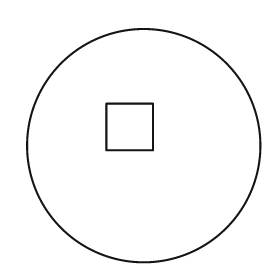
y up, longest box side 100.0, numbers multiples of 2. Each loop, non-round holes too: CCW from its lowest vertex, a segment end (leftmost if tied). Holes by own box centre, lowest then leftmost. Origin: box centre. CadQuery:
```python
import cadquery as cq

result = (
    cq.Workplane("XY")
    .moveTo(0.0, 0.0)
    .circle(50.0)
    .moveTo(-16.0, -2.0)
    .lineTo(4.0, -2.0)
    .lineTo(4.0, 18.0)
    .lineTo(-16.0, 18.0)
    .close()
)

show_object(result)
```